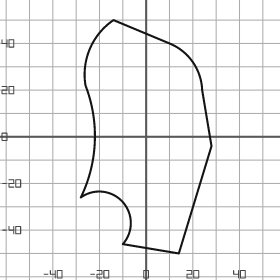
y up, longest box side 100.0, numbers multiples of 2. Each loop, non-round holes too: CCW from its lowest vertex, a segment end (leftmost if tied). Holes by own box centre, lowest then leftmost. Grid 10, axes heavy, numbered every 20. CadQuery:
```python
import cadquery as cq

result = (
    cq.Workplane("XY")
    .moveTo(14.0, -50.0)
    .lineTo(28.0, -4.0)
    .lineTo(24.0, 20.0)
    .threePointArc((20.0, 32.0), (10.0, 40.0))
    .lineTo(-14.0, 50.0)
    .threePointArc((-24.0, 38.0), (-26.0, 22.0))
    .threePointArc((-22.0, -2.0), (-28.0, -26.0))
    .threePointArc((-10.0, -28.0), (-10.0, -46.0))
    .close()
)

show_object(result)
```